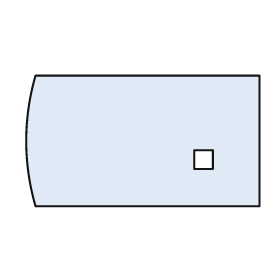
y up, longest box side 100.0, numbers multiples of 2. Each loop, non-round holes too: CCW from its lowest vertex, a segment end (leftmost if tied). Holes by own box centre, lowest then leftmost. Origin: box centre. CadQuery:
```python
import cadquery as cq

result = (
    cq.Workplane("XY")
    .moveTo(-46.0, -28.0)
    .lineTo(50.0, -28.0)
    .lineTo(50.0, 28.0)
    .lineTo(-46.0, 28.0)
    .threePointArc((-50.0, 0.0), (-46.0, -28.0))
    .close()
    .moveTo(22.0, -12.0)
    .lineTo(30.0, -12.0)
    .lineTo(30.0, -4.0)
    .lineTo(22.0, -4.0)
    .close()
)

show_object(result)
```